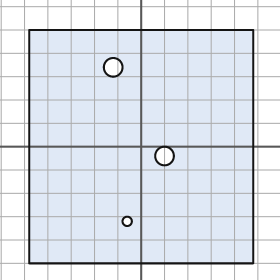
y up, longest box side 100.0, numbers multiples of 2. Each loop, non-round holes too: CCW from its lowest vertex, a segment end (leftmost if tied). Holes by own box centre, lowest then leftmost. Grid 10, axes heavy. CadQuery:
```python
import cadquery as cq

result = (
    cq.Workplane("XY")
    .moveTo(-48.0, -50.0)
    .lineTo(48.0, -50.0)
    .lineTo(48.0, 50.0)
    .lineTo(-48.0, 50.0)
    .close()
    .moveTo(-6.0, -32.0)
    .circle(2.0)
    .moveTo(10.0, -4.0)
    .circle(4.0)
    .moveTo(-12.0, 34.0)
    .circle(4.0)
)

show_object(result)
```